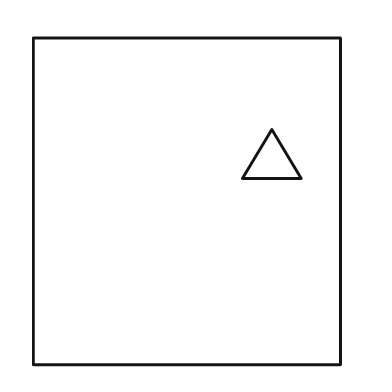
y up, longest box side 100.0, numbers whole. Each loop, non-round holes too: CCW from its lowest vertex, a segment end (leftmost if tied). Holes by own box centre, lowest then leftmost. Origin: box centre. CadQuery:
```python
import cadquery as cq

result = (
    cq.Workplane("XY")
    .moveTo(-47.0, -50.0)
    .lineTo(47.0, -50.0)
    .lineTo(47.0, 50.0)
    .lineTo(-47.0, 50.0)
    .close()
    .moveTo(17.0, 7.0)
    .lineTo(35.0, 7.0)
    .lineTo(26.0, 22.0)
    .close()
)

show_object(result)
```